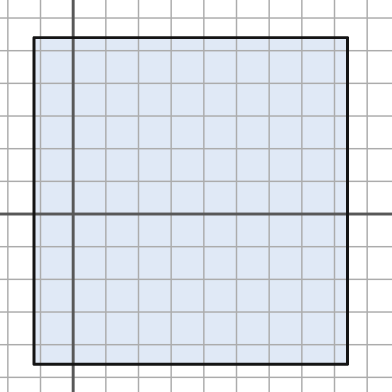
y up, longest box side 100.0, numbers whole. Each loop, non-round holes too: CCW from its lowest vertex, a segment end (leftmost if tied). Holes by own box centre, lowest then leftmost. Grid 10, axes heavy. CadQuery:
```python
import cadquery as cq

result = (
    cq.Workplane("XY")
    .moveTo(-12.0, -46.0)
    .lineTo(84.0, -46.0)
    .lineTo(84.0, 54.0)
    .lineTo(-12.0, 54.0)
    .close()
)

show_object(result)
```